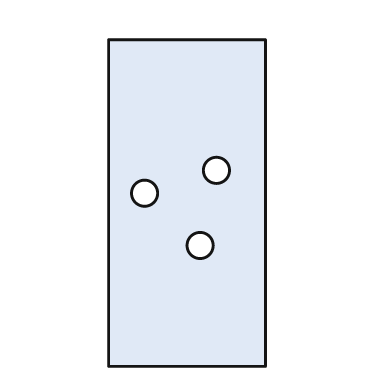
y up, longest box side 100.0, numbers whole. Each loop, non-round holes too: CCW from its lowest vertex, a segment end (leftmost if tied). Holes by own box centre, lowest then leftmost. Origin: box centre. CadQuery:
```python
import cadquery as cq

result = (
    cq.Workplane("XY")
    .moveTo(-24.0, -50.0)
    .lineTo(24.0, -50.0)
    .lineTo(24.0, 50.0)
    .lineTo(-24.0, 50.0)
    .close()
    .moveTo(4.0, -13.0)
    .circle(4.0)
    .moveTo(-13.0, 3.0)
    .circle(4.0)
    .moveTo(9.0, 10.0)
    .circle(4.0)
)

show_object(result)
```